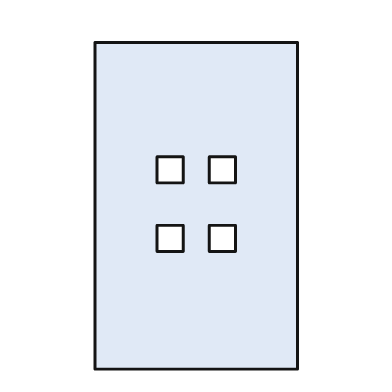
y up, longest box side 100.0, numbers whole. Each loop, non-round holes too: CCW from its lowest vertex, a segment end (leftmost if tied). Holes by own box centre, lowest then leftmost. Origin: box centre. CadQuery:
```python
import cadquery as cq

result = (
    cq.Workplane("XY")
    .moveTo(-31.0, -50.0)
    .lineTo(31.0, -50.0)
    .lineTo(31.0, 50.0)
    .lineTo(-31.0, 50.0)
    .close()
    .moveTo(-12.0, -14.0)
    .lineTo(-4.0, -14.0)
    .lineTo(-4.0, -6.0)
    .lineTo(-12.0, -6.0)
    .close()
    .moveTo(4.0, -14.0)
    .lineTo(12.0, -14.0)
    .lineTo(12.0, -6.0)
    .lineTo(4.0, -6.0)
    .close()
    .moveTo(-12.0, 7.0)
    .lineTo(-4.0, 7.0)
    .lineTo(-4.0, 15.0)
    .lineTo(-12.0, 15.0)
    .close()
    .moveTo(4.0, 7.0)
    .lineTo(12.0, 7.0)
    .lineTo(12.0, 15.0)
    .lineTo(4.0, 15.0)
    .close()
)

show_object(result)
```